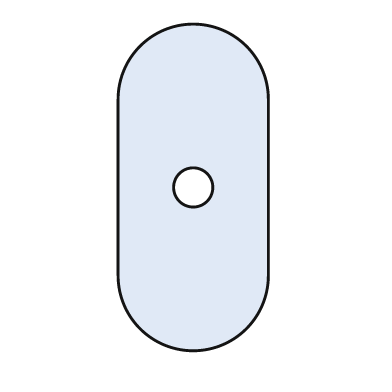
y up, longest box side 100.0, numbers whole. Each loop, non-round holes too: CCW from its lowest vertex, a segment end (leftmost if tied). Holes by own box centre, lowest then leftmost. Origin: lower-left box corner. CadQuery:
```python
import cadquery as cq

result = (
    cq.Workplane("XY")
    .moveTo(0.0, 23.0)
    .threePointArc((23.0, 0.0), (46.0, 23.0))
    .lineTo(46.0, 77.0)
    .threePointArc((23.0, 100.0), (0.0, 77.0))
    .close()
    .moveTo(23.0, 50.0)
    .circle(6.0)
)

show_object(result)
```